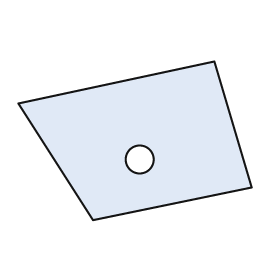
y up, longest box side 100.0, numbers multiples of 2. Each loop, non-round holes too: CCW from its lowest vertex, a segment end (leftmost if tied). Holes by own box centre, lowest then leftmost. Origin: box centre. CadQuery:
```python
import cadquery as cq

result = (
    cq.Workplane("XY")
    .moveTo(-18.0, -34.0)
    .lineTo(50.0, -20.0)
    .lineTo(34.0, 34.0)
    .lineTo(-50.0, 16.0)
    .close()
    .moveTo(2.0, -8.0)
    .circle(6.0)
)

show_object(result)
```